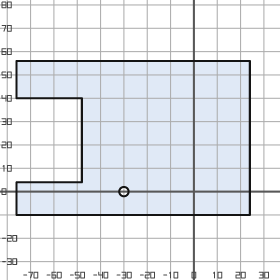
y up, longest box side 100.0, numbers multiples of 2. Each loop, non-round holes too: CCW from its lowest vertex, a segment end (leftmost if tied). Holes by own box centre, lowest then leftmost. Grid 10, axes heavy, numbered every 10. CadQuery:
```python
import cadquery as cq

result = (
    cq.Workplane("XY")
    .moveTo(-76.0, -10.0)
    .lineTo(24.0, -10.0)
    .lineTo(24.0, 56.0)
    .lineTo(-76.0, 56.0)
    .lineTo(-76.0, 40.0)
    .lineTo(-48.0, 40.0)
    .lineTo(-48.0, 4.0)
    .lineTo(-76.0, 4.0)
    .close()
    .moveTo(-30.0, 0.0)
    .circle(2.0)
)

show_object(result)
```